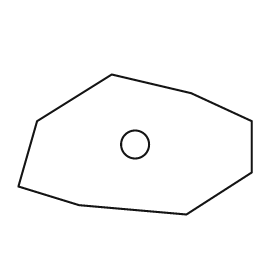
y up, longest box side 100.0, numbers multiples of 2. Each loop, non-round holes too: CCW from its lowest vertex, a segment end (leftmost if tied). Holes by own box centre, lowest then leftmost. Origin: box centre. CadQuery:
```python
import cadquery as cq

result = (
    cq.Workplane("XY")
    .moveTo(22.0, -30.0)
    .lineTo(50.0, -12.0)
    .lineTo(50.0, 10.0)
    .lineTo(24.0, 22.0)
    .lineTo(-10.0, 30.0)
    .lineTo(-42.0, 10.0)
    .lineTo(-50.0, -18.0)
    .lineTo(-24.0, -26.0)
    .close()
    .moveTo(0.0, 0.0)
    .circle(6.0)
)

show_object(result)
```